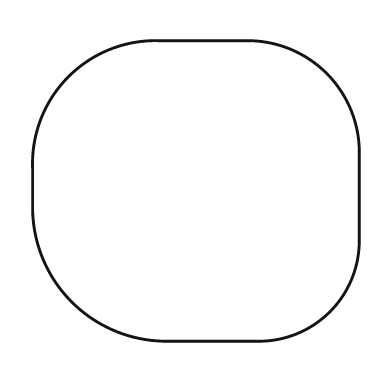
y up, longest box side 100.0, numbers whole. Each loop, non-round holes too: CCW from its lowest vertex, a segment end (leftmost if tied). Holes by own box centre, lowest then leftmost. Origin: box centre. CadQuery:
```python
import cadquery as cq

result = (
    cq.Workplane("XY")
    .moveTo(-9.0, -46.0)
    .lineTo(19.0, -46.0)
    .threePointArc((41.0, -37.0), (50.0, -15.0))
    .lineTo(50.0, 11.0)
    .threePointArc((40.0, 36.0), (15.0, 46.0))
    .lineTo(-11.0, 46.0)
    .threePointArc((-39.0, 35.0), (-50.0, 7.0))
    .lineTo(-50.0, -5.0)
    .threePointArc((-38.0, -34.0), (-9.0, -46.0))
    .close()
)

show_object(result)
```